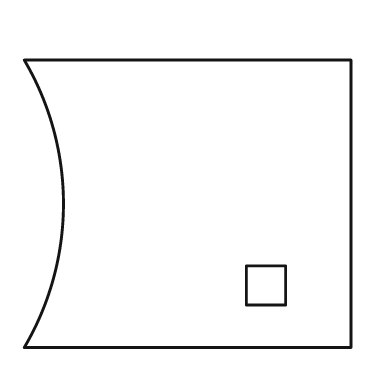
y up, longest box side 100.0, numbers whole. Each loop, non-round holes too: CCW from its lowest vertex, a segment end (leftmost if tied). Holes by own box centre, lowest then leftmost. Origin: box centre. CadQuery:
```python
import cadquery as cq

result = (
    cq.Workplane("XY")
    .moveTo(-50.0, -44.0)
    .lineTo(50.0, -44.0)
    .lineTo(50.0, 44.0)
    .lineTo(-50.0, 44.0)
    .threePointArc((-38.0, 0.0), (-50.0, -44.0))
    .close()
    .moveTo(18.0, -31.0)
    .lineTo(30.0, -31.0)
    .lineTo(30.0, -19.0)
    .lineTo(18.0, -19.0)
    .close()
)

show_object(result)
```